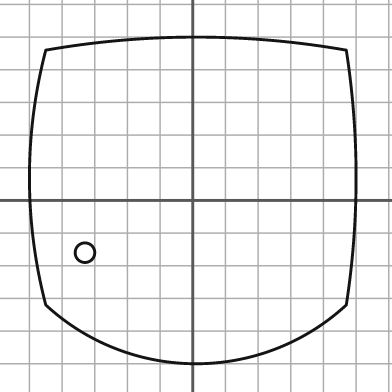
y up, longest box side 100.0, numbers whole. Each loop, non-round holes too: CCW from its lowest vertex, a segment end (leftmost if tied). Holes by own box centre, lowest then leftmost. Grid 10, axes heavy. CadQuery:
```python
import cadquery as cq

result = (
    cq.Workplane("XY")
    .moveTo(-45.0, -32.0)
    .threePointArc((1.0, -50.0), (47.0, -32.0))
    .threePointArc((50.0, 7.0), (47.0, 46.0))
    .threePointArc((1.0, 50.0), (-45.0, 46.0))
    .threePointArc((-50.0, 7.0), (-45.0, -32.0))
    .close()
    .moveTo(-33.0, -16.0)
    .circle(3.0)
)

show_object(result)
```